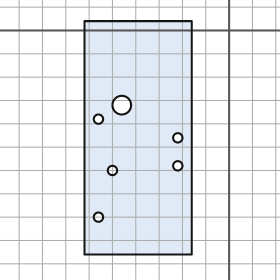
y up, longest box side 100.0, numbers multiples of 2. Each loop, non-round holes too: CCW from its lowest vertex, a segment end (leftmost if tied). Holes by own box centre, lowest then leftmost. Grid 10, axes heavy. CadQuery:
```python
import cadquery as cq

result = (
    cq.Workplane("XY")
    .moveTo(-62.0, -96.0)
    .lineTo(-16.0, -96.0)
    .lineTo(-16.0, 4.0)
    .lineTo(-62.0, 4.0)
    .close()
    .moveTo(-56.0, -80.0)
    .circle(2.0)
    .moveTo(-50.0, -60.0)
    .circle(2.0)
    .moveTo(-22.0, -58.0)
    .circle(2.0)
    .moveTo(-22.0, -46.0)
    .circle(2.0)
    .moveTo(-56.0, -38.0)
    .circle(2.0)
    .moveTo(-46.0, -32.0)
    .circle(4.0)
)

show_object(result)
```